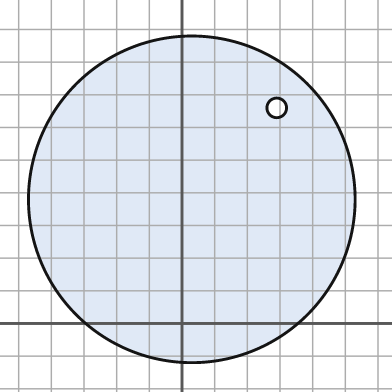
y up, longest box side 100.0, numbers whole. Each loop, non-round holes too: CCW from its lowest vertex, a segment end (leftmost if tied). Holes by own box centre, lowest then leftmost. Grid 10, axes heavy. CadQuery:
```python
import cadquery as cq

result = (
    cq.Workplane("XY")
    .moveTo(3.0, 38.0)
    .circle(50.0)
    .moveTo(29.0, 66.0)
    .circle(3.0)
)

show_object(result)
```